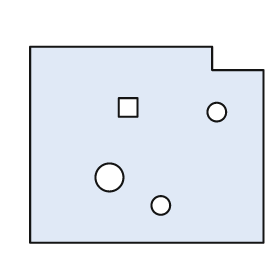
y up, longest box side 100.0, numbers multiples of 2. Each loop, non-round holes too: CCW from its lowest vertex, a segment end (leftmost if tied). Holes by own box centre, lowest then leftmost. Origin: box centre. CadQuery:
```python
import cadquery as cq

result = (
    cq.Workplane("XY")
    .moveTo(-50.0, -42.0)
    .lineTo(50.0, -42.0)
    .lineTo(50.0, 32.0)
    .lineTo(28.0, 32.0)
    .lineTo(28.0, 42.0)
    .lineTo(-50.0, 42.0)
    .close()
    .moveTo(6.0, -26.0)
    .circle(4.0)
    .moveTo(-16.0, -14.0)
    .circle(6.0)
    .moveTo(30.0, 14.0)
    .circle(4.0)
    .moveTo(-12.0, 12.0)
    .lineTo(-4.0, 12.0)
    .lineTo(-4.0, 20.0)
    .lineTo(-12.0, 20.0)
    .close()
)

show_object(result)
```